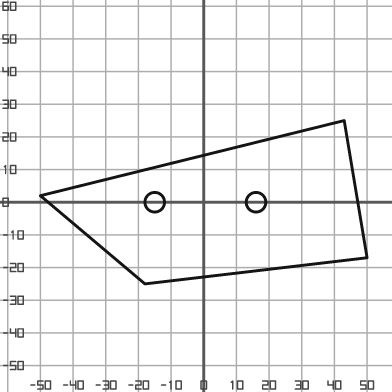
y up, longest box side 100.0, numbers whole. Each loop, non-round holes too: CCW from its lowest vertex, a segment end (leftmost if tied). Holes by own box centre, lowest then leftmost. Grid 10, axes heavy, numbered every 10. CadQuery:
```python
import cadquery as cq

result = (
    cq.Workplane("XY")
    .moveTo(-18.0, -25.0)
    .lineTo(50.0, -17.0)
    .lineTo(43.0, 25.0)
    .lineTo(-50.0, 2.0)
    .close()
    .moveTo(-15.0, 0.0)
    .circle(3.0)
    .moveTo(16.0, 0.0)
    .circle(3.0)
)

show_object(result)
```